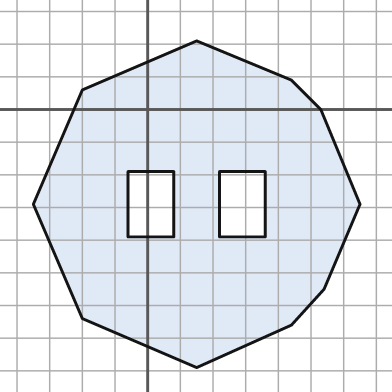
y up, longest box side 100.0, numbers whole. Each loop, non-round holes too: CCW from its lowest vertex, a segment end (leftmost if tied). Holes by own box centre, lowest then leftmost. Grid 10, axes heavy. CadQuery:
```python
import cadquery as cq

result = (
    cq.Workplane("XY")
    .moveTo(15.0, -79.0)
    .lineTo(44.0, -66.0)
    .lineTo(54.0, -55.0)
    .lineTo(65.0, -29.0)
    .lineTo(53.0, 0.0)
    .lineTo(44.0, 9.0)
    .lineTo(15.0, 21.0)
    .lineTo(-20.0, 6.0)
    .lineTo(-35.0, -29.0)
    .lineTo(-20.0, -64.0)
    .close()
    .moveTo(-6.0, -39.0)
    .lineTo(8.0, -39.0)
    .lineTo(8.0, -19.0)
    .lineTo(-6.0, -19.0)
    .close()
    .moveTo(22.0, -39.0)
    .lineTo(36.0, -39.0)
    .lineTo(36.0, -19.0)
    .lineTo(22.0, -19.0)
    .close()
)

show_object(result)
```